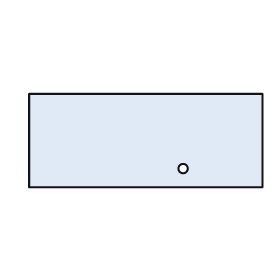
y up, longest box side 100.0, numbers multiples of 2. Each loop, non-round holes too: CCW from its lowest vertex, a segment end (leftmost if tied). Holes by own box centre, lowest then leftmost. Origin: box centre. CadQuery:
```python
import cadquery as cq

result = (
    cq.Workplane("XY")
    .moveTo(-50.0, -20.0)
    .lineTo(50.0, -20.0)
    .lineTo(50.0, 20.0)
    .lineTo(-50.0, 20.0)
    .close()
    .moveTo(16.0, -12.0)
    .circle(2.0)
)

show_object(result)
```